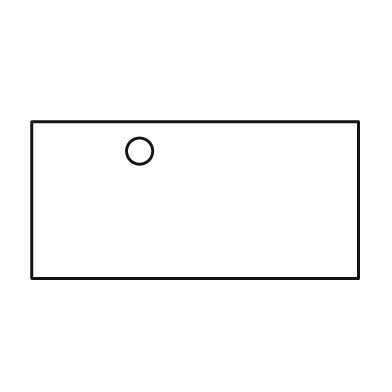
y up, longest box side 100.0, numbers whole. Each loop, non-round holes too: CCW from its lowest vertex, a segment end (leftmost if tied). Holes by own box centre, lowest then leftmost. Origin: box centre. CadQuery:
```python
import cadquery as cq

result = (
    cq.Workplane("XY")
    .moveTo(-50.0, -24.0)
    .lineTo(50.0, -24.0)
    .lineTo(50.0, 24.0)
    .lineTo(-50.0, 24.0)
    .close()
    .moveTo(-17.0, 15.0)
    .circle(4.0)
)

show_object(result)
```